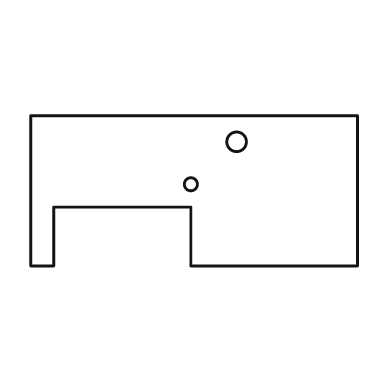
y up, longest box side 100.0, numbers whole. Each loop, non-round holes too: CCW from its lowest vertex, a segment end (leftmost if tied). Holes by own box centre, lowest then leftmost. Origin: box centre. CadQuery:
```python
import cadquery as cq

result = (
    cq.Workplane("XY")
    .moveTo(-50.0, -23.0)
    .lineTo(-43.0, -23.0)
    .lineTo(-43.0, -5.0)
    .lineTo(-1.0, -5.0)
    .lineTo(-1.0, -23.0)
    .lineTo(50.0, -23.0)
    .lineTo(50.0, 23.0)
    .lineTo(-50.0, 23.0)
    .close()
    .moveTo(-1.0, 2.0)
    .circle(2.0)
    .moveTo(13.0, 15.0)
    .circle(3.0)
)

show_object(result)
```